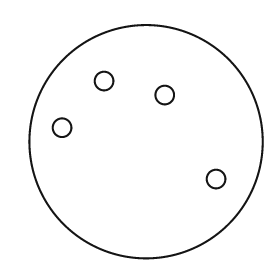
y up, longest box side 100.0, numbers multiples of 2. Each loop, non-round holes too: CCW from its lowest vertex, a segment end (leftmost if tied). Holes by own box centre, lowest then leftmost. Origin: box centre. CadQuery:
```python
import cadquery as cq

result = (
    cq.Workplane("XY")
    .moveTo(0.0, 0.0)
    .circle(50.0)
    .moveTo(30.0, -16.0)
    .circle(4.0)
    .moveTo(-36.0, 6.0)
    .circle(4.0)
    .moveTo(8.0, 20.0)
    .circle(4.0)
    .moveTo(-18.0, 26.0)
    .circle(4.0)
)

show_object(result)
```